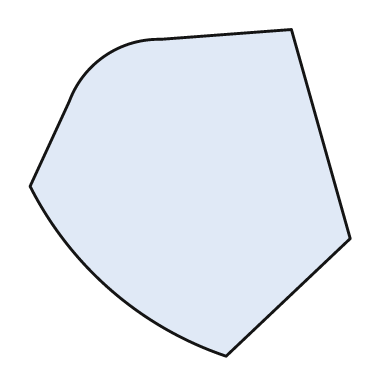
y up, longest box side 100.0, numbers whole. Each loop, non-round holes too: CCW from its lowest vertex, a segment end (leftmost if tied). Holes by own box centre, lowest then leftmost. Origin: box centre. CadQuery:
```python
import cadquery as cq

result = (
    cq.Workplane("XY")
    .moveTo(11.0, -50.0)
    .lineTo(49.0, -14.0)
    .lineTo(31.0, 50.0)
    .lineTo(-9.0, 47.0)
    .threePointArc((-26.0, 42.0), (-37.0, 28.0))
    .lineTo(-49.0, 2.0)
    .threePointArc((-24.0, -30.0), (11.0, -50.0))
    .close()
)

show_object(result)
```